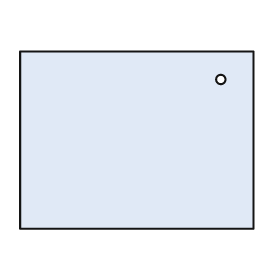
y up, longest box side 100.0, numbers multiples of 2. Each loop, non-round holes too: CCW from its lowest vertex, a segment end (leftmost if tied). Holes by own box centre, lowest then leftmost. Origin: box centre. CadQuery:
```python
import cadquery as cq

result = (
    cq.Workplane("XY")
    .moveTo(-50.0, -38.0)
    .lineTo(50.0, -38.0)
    .lineTo(50.0, 38.0)
    .lineTo(-50.0, 38.0)
    .close()
    .moveTo(36.0, 26.0)
    .circle(2.0)
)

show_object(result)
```